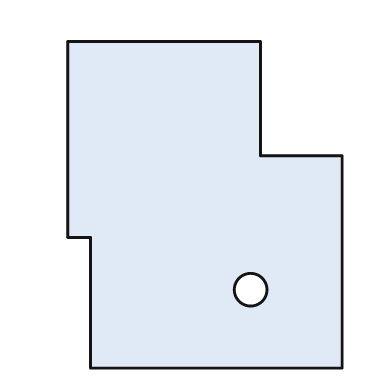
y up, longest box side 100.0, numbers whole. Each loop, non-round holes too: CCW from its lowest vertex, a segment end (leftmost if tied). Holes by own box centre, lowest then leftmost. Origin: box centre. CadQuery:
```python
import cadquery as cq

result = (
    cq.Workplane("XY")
    .moveTo(-35.0, -50.0)
    .lineTo(42.0, -50.0)
    .lineTo(42.0, 15.0)
    .lineTo(17.0, 15.0)
    .lineTo(17.0, 50.0)
    .lineTo(-42.0, 50.0)
    .lineTo(-42.0, -10.0)
    .lineTo(-35.0, -10.0)
    .close()
    .moveTo(14.0, -26.0)
    .circle(5.0)
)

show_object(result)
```